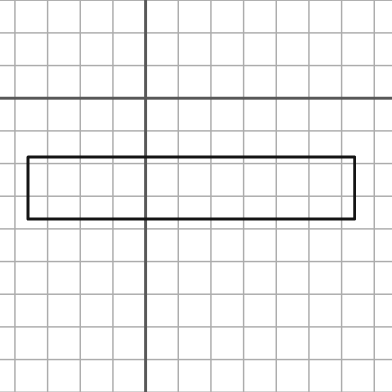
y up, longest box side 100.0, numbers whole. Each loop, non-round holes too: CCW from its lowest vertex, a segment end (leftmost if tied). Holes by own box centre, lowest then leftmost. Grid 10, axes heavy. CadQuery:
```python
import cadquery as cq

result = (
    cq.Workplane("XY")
    .moveTo(-36.0, -37.0)
    .lineTo(64.0, -37.0)
    .lineTo(64.0, -18.0)
    .lineTo(-36.0, -18.0)
    .close()
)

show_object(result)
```